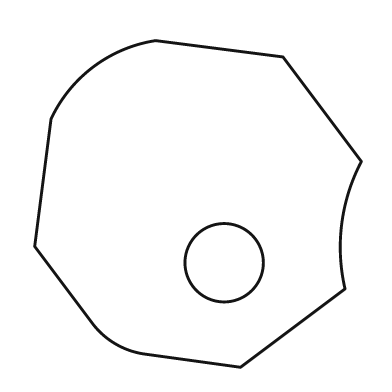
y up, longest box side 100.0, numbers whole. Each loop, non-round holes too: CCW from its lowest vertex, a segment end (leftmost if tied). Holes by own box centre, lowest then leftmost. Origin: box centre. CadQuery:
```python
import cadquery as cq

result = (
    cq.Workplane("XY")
    .moveTo(13.0, -50.0)
    .lineTo(45.0, -26.0)
    .threePointArc((44.0, -6.0), (50.0, 13.0))
    .lineTo(26.0, 45.0)
    .lineTo(-13.0, 50.0)
    .threePointArc((-32.0, 42.0), (-45.0, 26.0))
    .lineTo(-50.0, -13.0)
    .lineTo(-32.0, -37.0)
    .threePointArc((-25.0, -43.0), (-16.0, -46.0))
    .close()
    .moveTo(8.0, -18.0)
    .circle(12.0)
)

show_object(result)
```